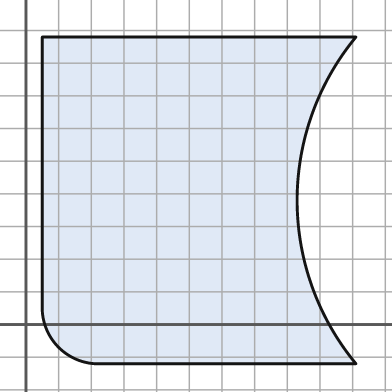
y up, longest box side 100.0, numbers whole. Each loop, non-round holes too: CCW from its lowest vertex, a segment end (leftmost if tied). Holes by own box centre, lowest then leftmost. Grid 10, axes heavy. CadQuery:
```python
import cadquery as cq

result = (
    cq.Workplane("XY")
    .moveTo(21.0, -12.0)
    .lineTo(101.0, -12.0)
    .threePointArc((83.0, 38.0), (101.0, 88.0))
    .lineTo(5.0, 88.0)
    .lineTo(5.0, 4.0)
    .threePointArc((10.0, -7.0), (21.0, -12.0))
    .close()
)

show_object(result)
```